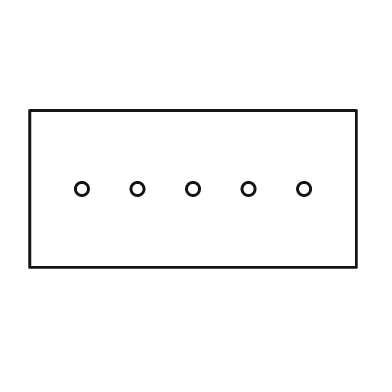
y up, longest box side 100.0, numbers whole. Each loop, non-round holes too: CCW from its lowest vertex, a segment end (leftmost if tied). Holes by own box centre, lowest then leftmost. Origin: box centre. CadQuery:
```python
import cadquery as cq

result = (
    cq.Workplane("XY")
    .moveTo(-50.0, -24.0)
    .lineTo(50.0, -24.0)
    .lineTo(50.0, 24.0)
    .lineTo(-50.0, 24.0)
    .close()
    .moveTo(-34.0, 0.0)
    .circle(2.0)
    .moveTo(-17.0, 0.0)
    .circle(2.0)
    .moveTo(0.0, 0.0)
    .circle(2.0)
    .moveTo(17.0, 0.0)
    .circle(2.0)
    .moveTo(34.0, 0.0)
    .circle(2.0)
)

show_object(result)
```